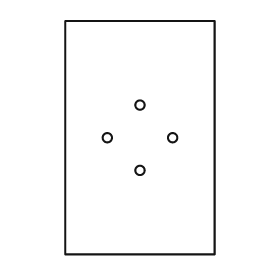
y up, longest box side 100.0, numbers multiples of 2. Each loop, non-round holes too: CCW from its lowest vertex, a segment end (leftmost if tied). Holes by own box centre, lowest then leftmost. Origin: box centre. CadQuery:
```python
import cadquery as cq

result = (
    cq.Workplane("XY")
    .moveTo(-32.0, -50.0)
    .lineTo(32.0, -50.0)
    .lineTo(32.0, 50.0)
    .lineTo(-32.0, 50.0)
    .close()
    .moveTo(0.0, -14.0)
    .circle(2.0)
    .moveTo(-14.0, 0.0)
    .circle(2.0)
    .moveTo(14.0, 0.0)
    .circle(2.0)
    .moveTo(0.0, 14.0)
    .circle(2.0)
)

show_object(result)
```